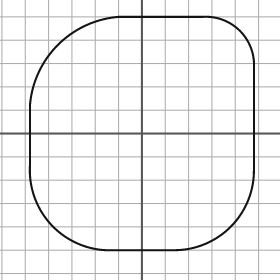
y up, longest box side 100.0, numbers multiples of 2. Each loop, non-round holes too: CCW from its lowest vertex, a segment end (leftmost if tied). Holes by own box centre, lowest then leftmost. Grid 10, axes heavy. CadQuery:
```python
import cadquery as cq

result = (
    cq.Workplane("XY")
    .moveTo(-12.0, -50.0)
    .lineTo(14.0, -50.0)
    .threePointArc((38.0, -40.0), (48.0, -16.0))
    .lineTo(48.0, 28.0)
    .threePointArc((42.0, 44.0), (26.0, 50.0))
    .lineTo(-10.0, 50.0)
    .threePointArc((-36.0, 38.0), (-48.0, 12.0))
    .lineTo(-48.0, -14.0)
    .threePointArc((-38.0, -40.0), (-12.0, -50.0))
    .close()
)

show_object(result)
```